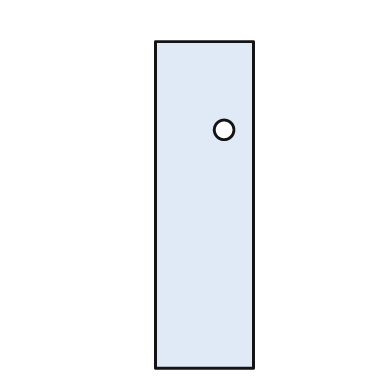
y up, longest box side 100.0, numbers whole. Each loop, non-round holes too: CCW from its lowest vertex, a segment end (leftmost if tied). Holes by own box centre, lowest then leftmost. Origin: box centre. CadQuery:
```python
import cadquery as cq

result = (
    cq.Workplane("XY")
    .moveTo(-15.0, -50.0)
    .lineTo(15.0, -50.0)
    .lineTo(15.0, 50.0)
    .lineTo(-15.0, 50.0)
    .close()
    .moveTo(6.0, 23.0)
    .circle(3.0)
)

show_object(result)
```